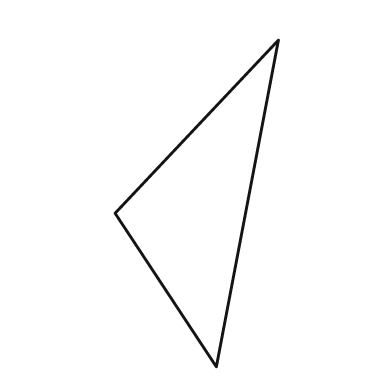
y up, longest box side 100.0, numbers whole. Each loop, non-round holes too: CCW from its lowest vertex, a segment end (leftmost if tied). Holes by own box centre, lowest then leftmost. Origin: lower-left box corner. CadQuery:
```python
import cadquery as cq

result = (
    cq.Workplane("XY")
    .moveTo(31.0, 0.0)
    .lineTo(50.0, 100.0)
    .lineTo(0.0, 47.0)
    .close()
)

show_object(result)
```